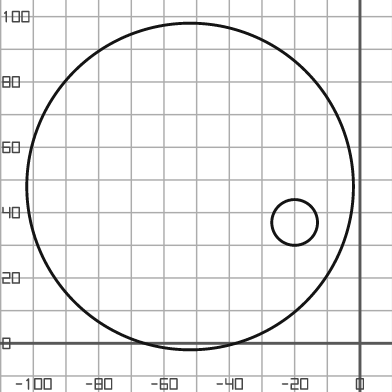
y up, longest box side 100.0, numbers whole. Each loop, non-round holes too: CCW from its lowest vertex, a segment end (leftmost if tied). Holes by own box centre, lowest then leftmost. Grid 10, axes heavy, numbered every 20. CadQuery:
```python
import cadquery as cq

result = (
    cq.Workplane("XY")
    .moveTo(-52.0, 48.0)
    .circle(50.0)
    .moveTo(-20.0, 37.0)
    .circle(7.0)
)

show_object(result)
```